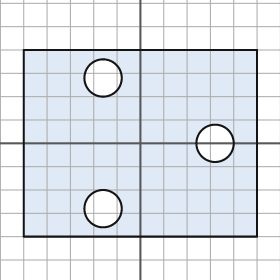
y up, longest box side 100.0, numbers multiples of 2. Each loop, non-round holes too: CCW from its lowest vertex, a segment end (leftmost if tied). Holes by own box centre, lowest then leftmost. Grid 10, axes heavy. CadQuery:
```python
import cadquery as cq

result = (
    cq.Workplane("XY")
    .moveTo(-50.0, -40.0)
    .lineTo(50.0, -40.0)
    .lineTo(50.0, 40.0)
    .lineTo(-50.0, 40.0)
    .close()
    .moveTo(-16.0, -28.0)
    .circle(8.0)
    .moveTo(32.0, 0.0)
    .circle(8.0)
    .moveTo(-16.0, 28.0)
    .circle(8.0)
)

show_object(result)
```